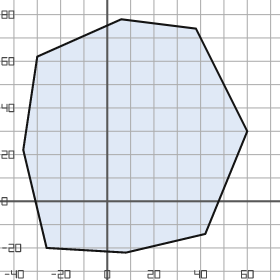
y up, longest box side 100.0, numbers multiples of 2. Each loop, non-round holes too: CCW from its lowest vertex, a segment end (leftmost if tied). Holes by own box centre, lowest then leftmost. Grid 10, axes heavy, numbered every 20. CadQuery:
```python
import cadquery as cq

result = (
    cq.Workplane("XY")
    .moveTo(8.0, -22.0)
    .lineTo(42.0, -14.0)
    .lineTo(60.0, 30.0)
    .lineTo(38.0, 74.0)
    .lineTo(6.0, 78.0)
    .lineTo(-30.0, 62.0)
    .lineTo(-36.0, 22.0)
    .lineTo(-26.0, -20.0)
    .close()
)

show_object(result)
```